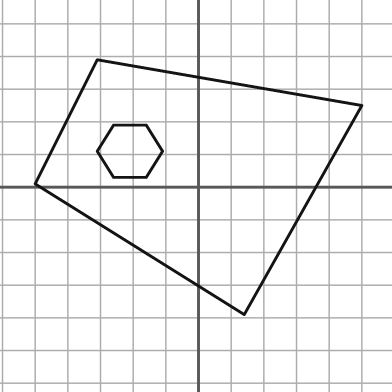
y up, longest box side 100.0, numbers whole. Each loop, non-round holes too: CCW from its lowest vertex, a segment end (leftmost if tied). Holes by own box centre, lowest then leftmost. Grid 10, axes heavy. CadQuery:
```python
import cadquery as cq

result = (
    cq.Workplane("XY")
    .moveTo(14.0, -39.0)
    .lineTo(50.0, 25.0)
    .lineTo(-31.0, 39.0)
    .lineTo(-50.0, 1.0)
    .close()
    .moveTo(-26.0, 3.0)
    .lineTo(-16.0, 3.0)
    .lineTo(-11.0, 11.0)
    .lineTo(-16.0, 19.0)
    .lineTo(-26.0, 19.0)
    .lineTo(-31.0, 11.0)
    .close()
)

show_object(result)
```